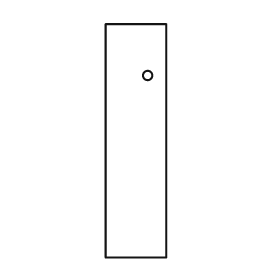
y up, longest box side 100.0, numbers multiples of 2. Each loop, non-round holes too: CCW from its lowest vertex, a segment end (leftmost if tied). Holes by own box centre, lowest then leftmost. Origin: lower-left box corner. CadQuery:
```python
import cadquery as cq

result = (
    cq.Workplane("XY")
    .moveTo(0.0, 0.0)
    .lineTo(26.0, 0.0)
    .lineTo(26.0, 100.0)
    .lineTo(0.0, 100.0)
    .close()
    .moveTo(18.0, 78.0)
    .circle(2.0)
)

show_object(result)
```